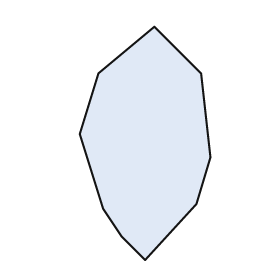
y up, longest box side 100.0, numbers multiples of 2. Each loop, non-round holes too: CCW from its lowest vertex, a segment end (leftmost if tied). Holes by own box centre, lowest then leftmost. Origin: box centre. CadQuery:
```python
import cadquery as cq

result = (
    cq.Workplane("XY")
    .moveTo(0.0, -50.0)
    .lineTo(22.0, -26.0)
    .lineTo(28.0, -6.0)
    .lineTo(24.0, 30.0)
    .lineTo(4.0, 50.0)
    .lineTo(-20.0, 30.0)
    .lineTo(-28.0, 4.0)
    .lineTo(-18.0, -28.0)
    .lineTo(-10.0, -40.0)
    .close()
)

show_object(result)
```